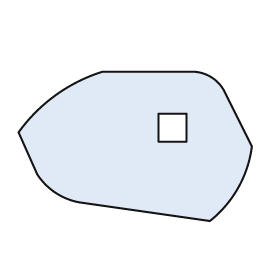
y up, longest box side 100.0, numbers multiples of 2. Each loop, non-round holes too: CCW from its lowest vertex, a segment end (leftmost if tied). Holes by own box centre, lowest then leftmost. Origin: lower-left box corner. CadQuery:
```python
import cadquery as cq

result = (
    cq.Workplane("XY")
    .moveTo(82.0, 0.0)
    .threePointArc((94.0, 14.0), (100.0, 32.0))
    .lineTo(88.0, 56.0)
    .threePointArc((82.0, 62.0), (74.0, 64.0))
    .lineTo(36.0, 64.0)
    .threePointArc((16.0, 54.0), (0.0, 38.0))
    .lineTo(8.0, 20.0)
    .threePointArc((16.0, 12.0), (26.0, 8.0))
    .close()
    .moveTo(60.0, 34.0)
    .lineTo(72.0, 34.0)
    .lineTo(72.0, 46.0)
    .lineTo(60.0, 46.0)
    .close()
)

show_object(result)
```